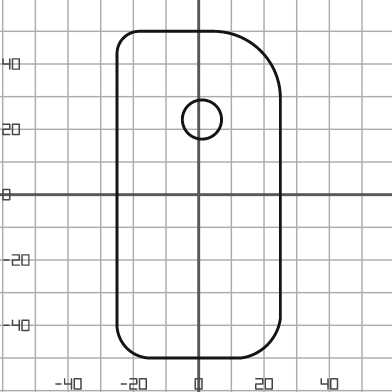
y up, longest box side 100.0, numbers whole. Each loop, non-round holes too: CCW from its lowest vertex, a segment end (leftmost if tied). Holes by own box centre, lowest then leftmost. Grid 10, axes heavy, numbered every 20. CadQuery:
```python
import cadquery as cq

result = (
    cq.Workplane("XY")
    .moveTo(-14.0, -50.0)
    .lineTo(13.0, -50.0)
    .threePointArc((21.0, -46.0), (25.0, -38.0))
    .lineTo(25.0, 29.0)
    .threePointArc((19.0, 44.0), (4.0, 50.0))
    .lineTo(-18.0, 50.0)
    .threePointArc((-23.0, 48.0), (-25.0, 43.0))
    .lineTo(-25.0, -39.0)
    .threePointArc((-22.0, -47.0), (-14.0, -50.0))
    .close()
    .moveTo(1.0, 23.0)
    .circle(6.0)
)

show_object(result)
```